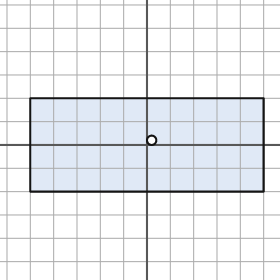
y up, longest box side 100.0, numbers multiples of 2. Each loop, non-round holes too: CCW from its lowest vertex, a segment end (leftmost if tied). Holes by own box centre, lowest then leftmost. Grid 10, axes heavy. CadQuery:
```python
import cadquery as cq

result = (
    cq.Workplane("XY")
    .moveTo(-50.0, -20.0)
    .lineTo(50.0, -20.0)
    .lineTo(50.0, 20.0)
    .lineTo(-50.0, 20.0)
    .close()
    .moveTo(2.0, 2.0)
    .circle(2.0)
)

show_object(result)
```